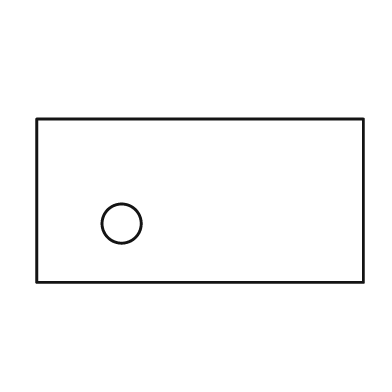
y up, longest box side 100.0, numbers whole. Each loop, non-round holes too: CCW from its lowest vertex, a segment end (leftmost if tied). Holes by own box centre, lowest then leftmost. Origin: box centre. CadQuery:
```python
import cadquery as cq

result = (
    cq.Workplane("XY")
    .moveTo(-50.0, -25.0)
    .lineTo(50.0, -25.0)
    .lineTo(50.0, 25.0)
    .lineTo(-50.0, 25.0)
    .close()
    .moveTo(-24.0, -7.0)
    .circle(6.0)
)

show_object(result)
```